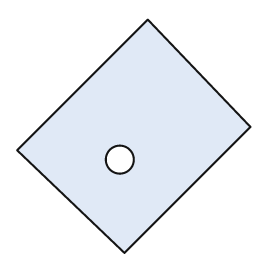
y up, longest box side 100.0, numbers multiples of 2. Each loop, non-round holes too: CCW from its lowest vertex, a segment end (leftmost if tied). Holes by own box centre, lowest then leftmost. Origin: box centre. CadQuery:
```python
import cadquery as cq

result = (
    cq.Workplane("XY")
    .moveTo(-4.0, -50.0)
    .lineTo(50.0, 4.0)
    .lineTo(6.0, 50.0)
    .lineTo(-50.0, -6.0)
    .close()
    .moveTo(-6.0, -10.0)
    .circle(6.0)
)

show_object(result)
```